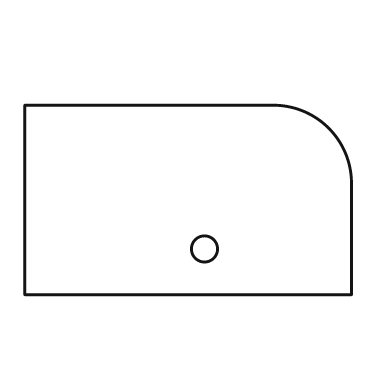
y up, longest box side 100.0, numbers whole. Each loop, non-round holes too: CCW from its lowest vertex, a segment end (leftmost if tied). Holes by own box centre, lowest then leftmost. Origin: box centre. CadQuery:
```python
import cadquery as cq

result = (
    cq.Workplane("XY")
    .moveTo(-50.0, -29.0)
    .lineTo(50.0, -29.0)
    .lineTo(50.0, 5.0)
    .threePointArc((43.0, 22.0), (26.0, 29.0))
    .lineTo(-50.0, 29.0)
    .close()
    .moveTo(5.0, -15.0)
    .circle(4.0)
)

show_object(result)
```